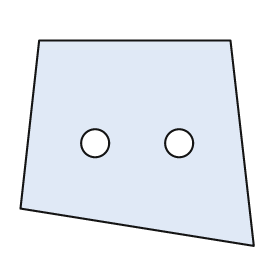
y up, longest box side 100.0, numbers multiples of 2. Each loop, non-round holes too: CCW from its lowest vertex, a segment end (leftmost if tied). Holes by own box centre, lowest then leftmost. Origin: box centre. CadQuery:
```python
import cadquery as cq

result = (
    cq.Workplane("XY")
    .moveTo(50.0, -44.0)
    .lineTo(40.0, 44.0)
    .lineTo(-42.0, 44.0)
    .lineTo(-50.0, -28.0)
    .close()
    .moveTo(-18.0, 0.0)
    .circle(6.0)
    .moveTo(18.0, 0.0)
    .circle(6.0)
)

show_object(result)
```